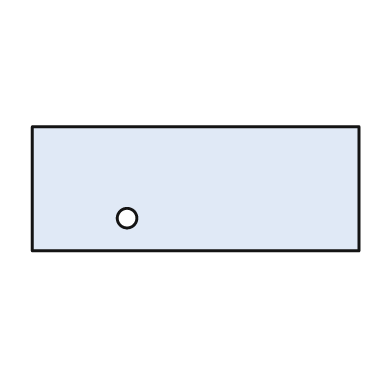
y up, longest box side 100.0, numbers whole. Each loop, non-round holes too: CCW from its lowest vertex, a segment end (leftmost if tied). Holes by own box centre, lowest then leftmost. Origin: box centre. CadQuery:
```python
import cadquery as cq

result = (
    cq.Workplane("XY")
    .moveTo(-50.0, -19.0)
    .lineTo(50.0, -19.0)
    .lineTo(50.0, 19.0)
    .lineTo(-50.0, 19.0)
    .close()
    .moveTo(-21.0, -9.0)
    .circle(3.0)
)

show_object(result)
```